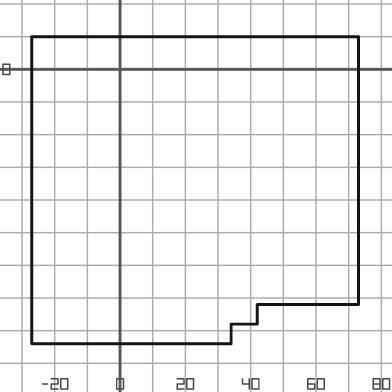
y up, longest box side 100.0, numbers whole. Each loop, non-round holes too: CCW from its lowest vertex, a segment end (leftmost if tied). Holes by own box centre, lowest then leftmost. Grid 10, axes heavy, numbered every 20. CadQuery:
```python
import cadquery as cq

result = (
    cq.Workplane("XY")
    .moveTo(-27.0, -84.0)
    .lineTo(34.0, -84.0)
    .lineTo(34.0, -78.0)
    .lineTo(42.0, -78.0)
    .lineTo(42.0, -72.0)
    .lineTo(73.0, -72.0)
    .lineTo(73.0, 10.0)
    .lineTo(-27.0, 10.0)
    .close()
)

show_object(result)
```